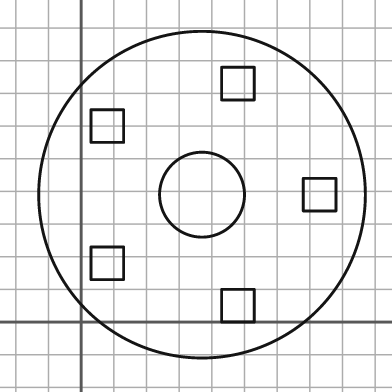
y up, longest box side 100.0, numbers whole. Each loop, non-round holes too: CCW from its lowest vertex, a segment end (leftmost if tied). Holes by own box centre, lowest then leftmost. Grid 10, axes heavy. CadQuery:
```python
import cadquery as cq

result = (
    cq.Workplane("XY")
    .moveTo(37.0, 39.0)
    .circle(50.0)
    .moveTo(43.0, 0.0)
    .lineTo(53.0, 0.0)
    .lineTo(53.0, 10.0)
    .lineTo(43.0, 10.0)
    .close()
    .moveTo(3.0, 13.0)
    .lineTo(13.0, 13.0)
    .lineTo(13.0, 23.0)
    .lineTo(3.0, 23.0)
    .close()
    .moveTo(37.0, 39.0)
    .circle(13.0)
    .moveTo(68.0, 34.0)
    .lineTo(78.0, 34.0)
    .lineTo(78.0, 44.0)
    .lineTo(68.0, 44.0)
    .close()
    .moveTo(3.0, 55.0)
    .lineTo(13.0, 55.0)
    .lineTo(13.0, 65.0)
    .lineTo(3.0, 65.0)
    .close()
    .moveTo(43.0, 68.0)
    .lineTo(53.0, 68.0)
    .lineTo(53.0, 78.0)
    .lineTo(43.0, 78.0)
    .close()
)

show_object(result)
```